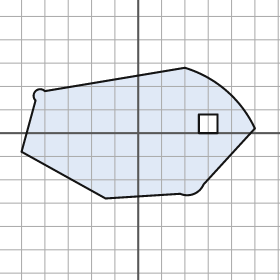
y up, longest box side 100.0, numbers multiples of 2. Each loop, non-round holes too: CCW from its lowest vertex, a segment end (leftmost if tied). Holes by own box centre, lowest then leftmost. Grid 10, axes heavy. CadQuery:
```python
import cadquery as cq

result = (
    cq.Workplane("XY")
    .moveTo(-14.0, -28.0)
    .lineTo(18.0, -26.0)
    .threePointArc((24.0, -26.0), (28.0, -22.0))
    .lineTo(50.0, 2.0)
    .threePointArc((38.0, 18.0), (20.0, 28.0))
    .lineTo(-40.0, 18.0)
    .threePointArc((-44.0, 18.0), (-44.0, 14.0))
    .lineTo(-50.0, -8.0)
    .close()
    .moveTo(26.0, 0.0)
    .lineTo(34.0, 0.0)
    .lineTo(34.0, 8.0)
    .lineTo(26.0, 8.0)
    .close()
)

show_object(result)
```